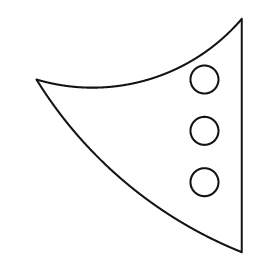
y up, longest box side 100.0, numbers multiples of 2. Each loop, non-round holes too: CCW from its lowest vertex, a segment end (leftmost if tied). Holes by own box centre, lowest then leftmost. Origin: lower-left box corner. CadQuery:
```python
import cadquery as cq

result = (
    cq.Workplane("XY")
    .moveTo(88.0, 0.0)
    .lineTo(88.0, 100.0)
    .threePointArc((48.0, 74.0), (0.0, 74.0))
    .threePointArc((38.0, 30.0), (88.0, 0.0))
    .close()
    .moveTo(72.0, 30.0)
    .circle(6.0)
    .moveTo(72.0, 52.0)
    .circle(6.0)
    .moveTo(72.0, 74.0)
    .circle(6.0)
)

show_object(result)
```